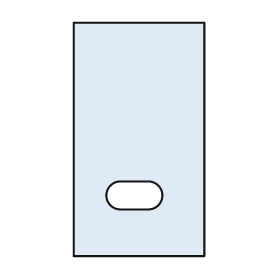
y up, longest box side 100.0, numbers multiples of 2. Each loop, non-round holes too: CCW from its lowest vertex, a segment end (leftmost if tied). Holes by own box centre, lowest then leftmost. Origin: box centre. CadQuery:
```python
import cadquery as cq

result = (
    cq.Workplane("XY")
    .moveTo(-28.0, -50.0)
    .lineTo(28.0, -50.0)
    .lineTo(28.0, 50.0)
    .lineTo(-28.0, 50.0)
    .close()
    .moveTo(-8.0, -30.0)
    .lineTo(4.0, -30.0)
    .threePointArc((10.0, -24.0), (4.0, -18.0))
    .lineTo(-8.0, -18.0)
    .threePointArc((-14.0, -24.0), (-8.0, -30.0))
    .close()
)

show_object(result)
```